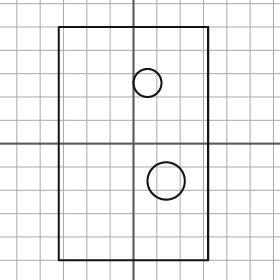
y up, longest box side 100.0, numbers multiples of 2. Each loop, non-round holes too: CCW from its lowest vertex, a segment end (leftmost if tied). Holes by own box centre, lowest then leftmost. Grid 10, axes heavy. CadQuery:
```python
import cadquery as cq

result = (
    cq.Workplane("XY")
    .moveTo(-32.0, -50.0)
    .lineTo(32.0, -50.0)
    .lineTo(32.0, 50.0)
    .lineTo(-32.0, 50.0)
    .close()
    .moveTo(14.0, -16.0)
    .circle(8.0)
    .moveTo(6.0, 26.0)
    .circle(6.0)
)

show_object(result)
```